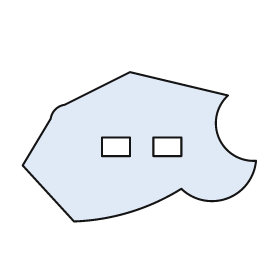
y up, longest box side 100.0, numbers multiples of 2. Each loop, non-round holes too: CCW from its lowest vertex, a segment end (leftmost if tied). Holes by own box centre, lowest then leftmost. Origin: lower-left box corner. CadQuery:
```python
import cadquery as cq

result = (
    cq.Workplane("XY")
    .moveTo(22.0, 0.0)
    .threePointArc((46.0, 4.0), (68.0, 14.0))
    .threePointArc((88.0, 10.0), (100.0, 26.0))
    .threePointArc((84.0, 36.0), (88.0, 54.0))
    .lineTo(46.0, 64.0)
    .lineTo(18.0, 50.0)
    .threePointArc((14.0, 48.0), (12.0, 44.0))
    .lineTo(0.0, 24.0)
    .close()
    .moveTo(34.0, 28.0)
    .lineTo(46.0, 28.0)
    .lineTo(46.0, 36.0)
    .lineTo(34.0, 36.0)
    .close()
    .moveTo(56.0, 28.0)
    .lineTo(68.0, 28.0)
    .lineTo(68.0, 36.0)
    .lineTo(56.0, 36.0)
    .close()
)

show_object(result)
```